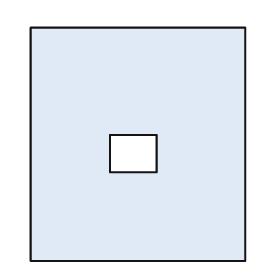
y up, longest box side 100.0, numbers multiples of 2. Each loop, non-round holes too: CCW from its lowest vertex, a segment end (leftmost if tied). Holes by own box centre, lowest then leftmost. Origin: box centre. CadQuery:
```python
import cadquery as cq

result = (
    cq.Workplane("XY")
    .moveTo(-46.0, -50.0)
    .lineTo(46.0, -50.0)
    .lineTo(46.0, 50.0)
    .lineTo(-46.0, 50.0)
    .close()
    .moveTo(-12.0, -12.0)
    .lineTo(8.0, -12.0)
    .lineTo(8.0, 4.0)
    .lineTo(-12.0, 4.0)
    .close()
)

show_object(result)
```